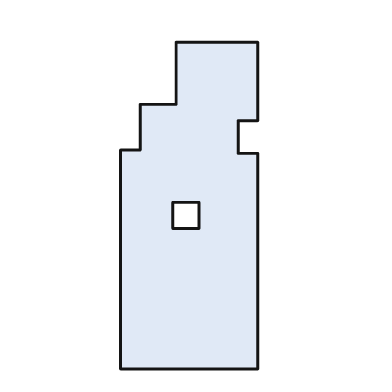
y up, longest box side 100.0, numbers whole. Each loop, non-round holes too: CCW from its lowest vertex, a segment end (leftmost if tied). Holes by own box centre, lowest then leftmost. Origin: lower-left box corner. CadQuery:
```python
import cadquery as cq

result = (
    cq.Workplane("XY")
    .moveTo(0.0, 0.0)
    .lineTo(42.0, 0.0)
    .lineTo(42.0, 66.0)
    .lineTo(36.0, 66.0)
    .lineTo(36.0, 76.0)
    .lineTo(42.0, 76.0)
    .lineTo(42.0, 100.0)
    .lineTo(17.0, 100.0)
    .lineTo(17.0, 81.0)
    .lineTo(6.0, 81.0)
    .lineTo(6.0, 67.0)
    .lineTo(0.0, 67.0)
    .close()
    .moveTo(16.0, 43.0)
    .lineTo(24.0, 43.0)
    .lineTo(24.0, 51.0)
    .lineTo(16.0, 51.0)
    .close()
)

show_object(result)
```